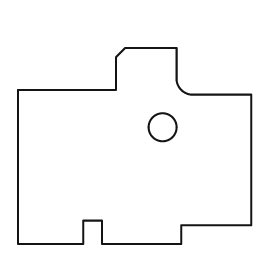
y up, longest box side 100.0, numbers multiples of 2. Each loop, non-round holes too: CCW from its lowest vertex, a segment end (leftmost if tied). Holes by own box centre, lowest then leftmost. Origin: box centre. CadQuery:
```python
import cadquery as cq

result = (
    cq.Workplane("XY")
    .moveTo(-50.0, -42.0)
    .lineTo(-22.0, -42.0)
    .lineTo(-22.0, -32.0)
    .lineTo(-14.0, -32.0)
    .lineTo(-14.0, -42.0)
    .lineTo(20.0, -42.0)
    .lineTo(20.0, -34.0)
    .lineTo(50.0, -34.0)
    .lineTo(50.0, 22.0)
    .lineTo(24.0, 22.0)
    .threePointArc((20.0, 24.0), (18.0, 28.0))
    .lineTo(18.0, 42.0)
    .lineTo(-4.0, 42.0)
    .lineTo(-8.0, 38.0)
    .lineTo(-8.0, 24.0)
    .lineTo(-50.0, 24.0)
    .close()
    .moveTo(12.0, 8.0)
    .circle(6.0)
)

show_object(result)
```